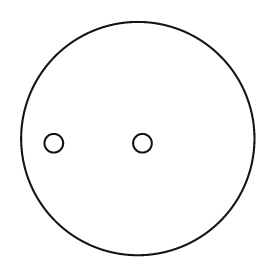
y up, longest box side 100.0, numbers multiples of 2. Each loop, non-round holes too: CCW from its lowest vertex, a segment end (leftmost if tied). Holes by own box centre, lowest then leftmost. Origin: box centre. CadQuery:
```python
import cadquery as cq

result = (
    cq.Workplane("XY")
    .moveTo(0.0, 0.0)
    .circle(50.0)
    .moveTo(-36.0, -2.0)
    .circle(4.0)
    .moveTo(2.0, -2.0)
    .circle(4.0)
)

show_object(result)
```